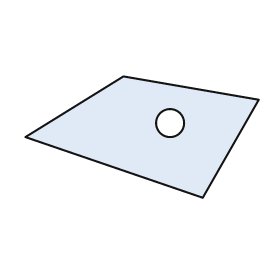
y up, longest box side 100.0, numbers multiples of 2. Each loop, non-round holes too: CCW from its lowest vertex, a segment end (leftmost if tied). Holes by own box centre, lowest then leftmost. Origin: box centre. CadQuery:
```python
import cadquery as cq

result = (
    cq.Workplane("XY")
    .moveTo(26.0, -26.0)
    .lineTo(50.0, 16.0)
    .lineTo(-8.0, 26.0)
    .lineTo(-50.0, 0.0)
    .close()
    .moveTo(12.0, 6.0)
    .circle(6.0)
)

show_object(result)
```